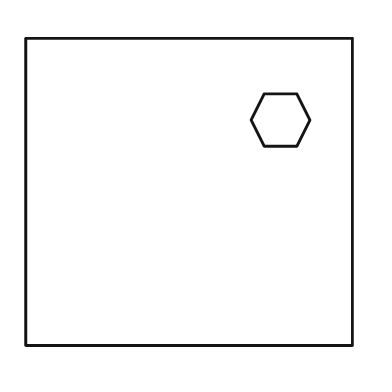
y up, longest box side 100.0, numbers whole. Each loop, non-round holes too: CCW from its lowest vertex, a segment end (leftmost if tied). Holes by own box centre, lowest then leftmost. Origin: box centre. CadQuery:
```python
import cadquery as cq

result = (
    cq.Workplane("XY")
    .moveTo(-50.0, -47.0)
    .lineTo(50.0, -47.0)
    .lineTo(50.0, 47.0)
    .lineTo(-50.0, 47.0)
    .close()
    .moveTo(23.0, 14.0)
    .lineTo(33.0, 14.0)
    .lineTo(37.0, 22.0)
    .lineTo(33.0, 30.0)
    .lineTo(23.0, 30.0)
    .lineTo(19.0, 22.0)
    .close()
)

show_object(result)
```